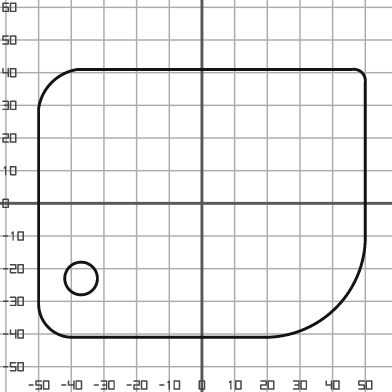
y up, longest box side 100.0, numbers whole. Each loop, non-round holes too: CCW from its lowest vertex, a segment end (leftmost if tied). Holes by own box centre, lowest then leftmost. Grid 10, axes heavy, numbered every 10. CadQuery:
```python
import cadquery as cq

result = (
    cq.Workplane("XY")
    .moveTo(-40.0, -41.0)
    .lineTo(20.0, -41.0)
    .threePointArc((41.0, -32.0), (50.0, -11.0))
    .lineTo(50.0, 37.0)
    .threePointArc((49.0, 40.0), (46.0, 41.0))
    .lineTo(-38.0, 41.0)
    .threePointArc((-46.0, 37.0), (-50.0, 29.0))
    .lineTo(-50.0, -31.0)
    .threePointArc((-47.0, -38.0), (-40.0, -41.0))
    .close()
    .moveTo(-37.0, -23.0)
    .circle(5.0)
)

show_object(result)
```